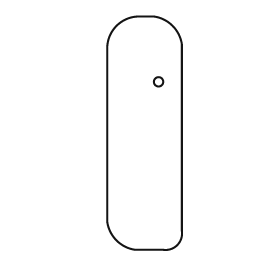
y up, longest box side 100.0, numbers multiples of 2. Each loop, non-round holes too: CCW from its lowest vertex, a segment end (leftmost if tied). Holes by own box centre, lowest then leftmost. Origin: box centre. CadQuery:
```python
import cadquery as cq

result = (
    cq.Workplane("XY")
    .moveTo(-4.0, -50.0)
    .lineTo(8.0, -50.0)
    .threePointArc((14.0, -48.0), (16.0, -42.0))
    .lineTo(16.0, 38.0)
    .threePointArc((12.0, 46.0), (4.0, 50.0))
    .lineTo(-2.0, 50.0)
    .threePointArc((-12.0, 46.0), (-16.0, 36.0))
    .lineTo(-16.0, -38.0)
    .threePointArc((-12.0, -46.0), (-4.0, -50.0))
    .close()
    .moveTo(6.0, 22.0)
    .circle(2.0)
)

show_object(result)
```